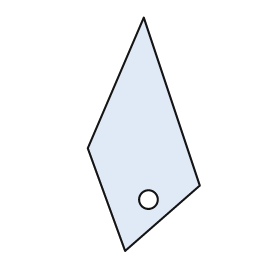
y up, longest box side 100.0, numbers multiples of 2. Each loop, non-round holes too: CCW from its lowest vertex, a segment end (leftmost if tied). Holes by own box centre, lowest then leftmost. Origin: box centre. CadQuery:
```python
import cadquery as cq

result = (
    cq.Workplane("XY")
    .moveTo(-8.0, -50.0)
    .lineTo(24.0, -22.0)
    .lineTo(0.0, 50.0)
    .lineTo(-24.0, -6.0)
    .close()
    .moveTo(2.0, -28.0)
    .circle(4.0)
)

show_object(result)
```